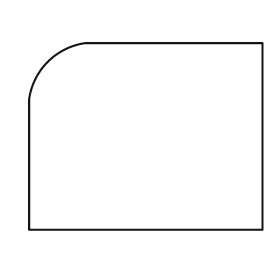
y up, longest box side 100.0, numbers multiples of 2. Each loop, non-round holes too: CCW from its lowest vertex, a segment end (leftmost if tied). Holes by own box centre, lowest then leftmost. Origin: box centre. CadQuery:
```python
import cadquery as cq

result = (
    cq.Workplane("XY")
    .moveTo(-50.0, -40.0)
    .lineTo(50.0, -40.0)
    .lineTo(50.0, 40.0)
    .lineTo(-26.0, 40.0)
    .threePointArc((-42.0, 32.0), (-50.0, 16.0))
    .close()
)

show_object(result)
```